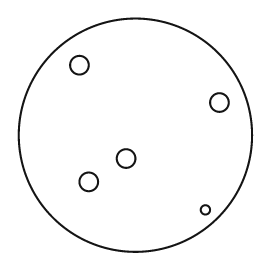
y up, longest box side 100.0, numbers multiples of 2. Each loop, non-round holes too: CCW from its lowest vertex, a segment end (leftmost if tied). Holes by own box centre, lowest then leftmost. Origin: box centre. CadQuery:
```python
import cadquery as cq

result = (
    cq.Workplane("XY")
    .moveTo(0.0, 0.0)
    .circle(50.0)
    .moveTo(30.0, -32.0)
    .circle(2.0)
    .moveTo(-20.0, -20.0)
    .circle(4.0)
    .moveTo(-4.0, -10.0)
    .circle(4.0)
    .moveTo(36.0, 14.0)
    .circle(4.0)
    .moveTo(-24.0, 30.0)
    .circle(4.0)
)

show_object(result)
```